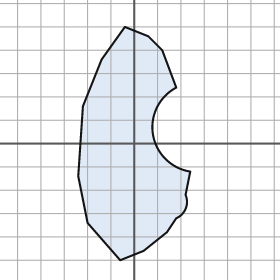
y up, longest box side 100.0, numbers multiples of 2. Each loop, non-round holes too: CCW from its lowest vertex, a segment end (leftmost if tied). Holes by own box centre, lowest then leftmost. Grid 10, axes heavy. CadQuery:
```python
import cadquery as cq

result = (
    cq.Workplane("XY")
    .moveTo(-6.0, -50.0)
    .lineTo(4.0, -46.0)
    .lineTo(14.0, -38.0)
    .lineTo(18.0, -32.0)
    .threePointArc((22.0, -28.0), (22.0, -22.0))
    .lineTo(24.0, -12.0)
    .threePointArc((8.0, 4.0), (18.0, 24.0))
    .lineTo(12.0, 40.0)
    .lineTo(6.0, 46.0)
    .lineTo(-4.0, 50.0)
    .lineTo(-14.0, 36.0)
    .lineTo(-22.0, 16.0)
    .lineTo(-24.0, -14.0)
    .lineTo(-20.0, -34.0)
    .close()
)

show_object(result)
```